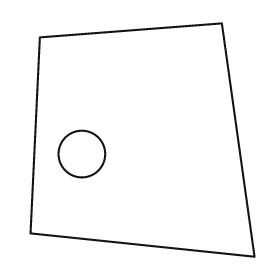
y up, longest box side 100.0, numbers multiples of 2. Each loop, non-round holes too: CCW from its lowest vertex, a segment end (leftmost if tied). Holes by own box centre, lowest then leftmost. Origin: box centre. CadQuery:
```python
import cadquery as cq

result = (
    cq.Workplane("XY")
    .moveTo(48.0, -50.0)
    .lineTo(34.0, 50.0)
    .lineTo(-44.0, 44.0)
    .lineTo(-48.0, -40.0)
    .close()
    .moveTo(-26.0, -6.0)
    .circle(10.0)
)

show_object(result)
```